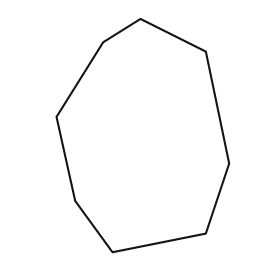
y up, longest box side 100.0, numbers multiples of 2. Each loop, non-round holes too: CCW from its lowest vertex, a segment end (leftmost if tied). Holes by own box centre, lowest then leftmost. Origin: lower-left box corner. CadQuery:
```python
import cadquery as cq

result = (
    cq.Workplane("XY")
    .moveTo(24.0, 0.0)
    .lineTo(64.0, 8.0)
    .lineTo(74.0, 38.0)
    .lineTo(64.0, 86.0)
    .lineTo(36.0, 100.0)
    .lineTo(20.0, 90.0)
    .lineTo(0.0, 58.0)
    .lineTo(8.0, 22.0)
    .close()
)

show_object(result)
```